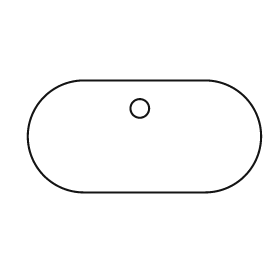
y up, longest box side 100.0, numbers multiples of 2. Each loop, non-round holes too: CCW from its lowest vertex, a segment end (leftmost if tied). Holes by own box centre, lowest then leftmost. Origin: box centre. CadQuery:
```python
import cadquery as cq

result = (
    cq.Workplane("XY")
    .moveTo(-26.0, -24.0)
    .lineTo(26.0, -24.0)
    .threePointArc((50.0, 0.0), (26.0, 24.0))
    .lineTo(-26.0, 24.0)
    .threePointArc((-50.0, 0.0), (-26.0, -24.0))
    .close()
    .moveTo(-2.0, 12.0)
    .circle(4.0)
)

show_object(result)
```